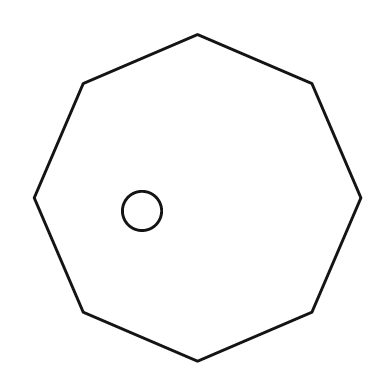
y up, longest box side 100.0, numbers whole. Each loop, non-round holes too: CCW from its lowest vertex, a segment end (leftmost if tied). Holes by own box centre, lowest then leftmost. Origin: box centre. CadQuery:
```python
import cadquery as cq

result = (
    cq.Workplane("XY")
    .moveTo(0.0, -50.0)
    .lineTo(35.0, -35.0)
    .lineTo(50.0, 0.0)
    .lineTo(35.0, 35.0)
    .lineTo(0.0, 50.0)
    .lineTo(-35.0, 35.0)
    .lineTo(-50.0, 0.0)
    .lineTo(-35.0, -35.0)
    .close()
    .moveTo(-17.0, -4.0)
    .circle(6.0)
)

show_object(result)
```